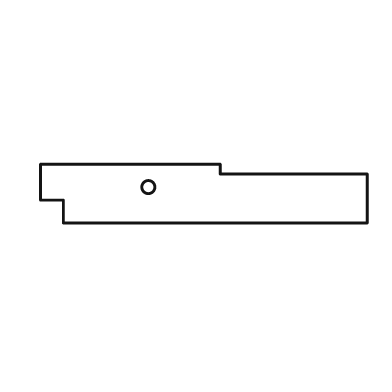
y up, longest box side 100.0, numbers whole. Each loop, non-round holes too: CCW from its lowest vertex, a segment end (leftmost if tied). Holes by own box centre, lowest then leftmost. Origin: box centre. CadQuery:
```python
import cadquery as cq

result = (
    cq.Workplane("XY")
    .moveTo(-43.0, -9.0)
    .lineTo(50.0, -9.0)
    .lineTo(50.0, 6.0)
    .lineTo(5.0, 6.0)
    .lineTo(5.0, 9.0)
    .lineTo(-50.0, 9.0)
    .lineTo(-50.0, -2.0)
    .lineTo(-43.0, -2.0)
    .close()
    .moveTo(-17.0, 2.0)
    .circle(2.0)
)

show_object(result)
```